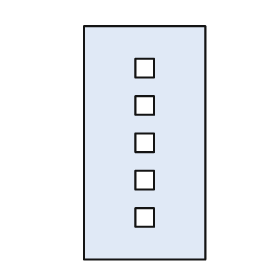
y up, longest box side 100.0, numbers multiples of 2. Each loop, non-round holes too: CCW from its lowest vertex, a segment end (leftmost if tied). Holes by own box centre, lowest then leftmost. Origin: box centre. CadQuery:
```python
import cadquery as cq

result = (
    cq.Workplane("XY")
    .moveTo(-26.0, -50.0)
    .lineTo(26.0, -50.0)
    .lineTo(26.0, 50.0)
    .lineTo(-26.0, 50.0)
    .close()
    .moveTo(-4.0, -36.0)
    .lineTo(4.0, -36.0)
    .lineTo(4.0, -28.0)
    .lineTo(-4.0, -28.0)
    .close()
    .moveTo(-4.0, -20.0)
    .lineTo(4.0, -20.0)
    .lineTo(4.0, -12.0)
    .lineTo(-4.0, -12.0)
    .close()
    .moveTo(-4.0, -4.0)
    .lineTo(4.0, -4.0)
    .lineTo(4.0, 4.0)
    .lineTo(-4.0, 4.0)
    .close()
    .moveTo(-4.0, 12.0)
    .lineTo(4.0, 12.0)
    .lineTo(4.0, 20.0)
    .lineTo(-4.0, 20.0)
    .close()
    .moveTo(-4.0, 28.0)
    .lineTo(4.0, 28.0)
    .lineTo(4.0, 36.0)
    .lineTo(-4.0, 36.0)
    .close()
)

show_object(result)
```